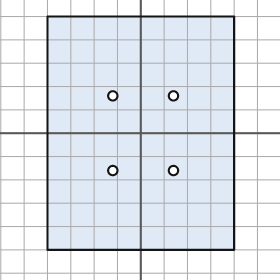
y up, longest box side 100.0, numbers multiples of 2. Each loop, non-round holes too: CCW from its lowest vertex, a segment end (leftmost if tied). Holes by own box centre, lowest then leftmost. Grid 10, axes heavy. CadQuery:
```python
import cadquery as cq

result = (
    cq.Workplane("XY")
    .moveTo(-40.0, -50.0)
    .lineTo(40.0, -50.0)
    .lineTo(40.0, 50.0)
    .lineTo(-40.0, 50.0)
    .close()
    .moveTo(-12.0, -16.0)
    .circle(2.0)
    .moveTo(14.0, -16.0)
    .circle(2.0)
    .moveTo(-12.0, 16.0)
    .circle(2.0)
    .moveTo(14.0, 16.0)
    .circle(2.0)
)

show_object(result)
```